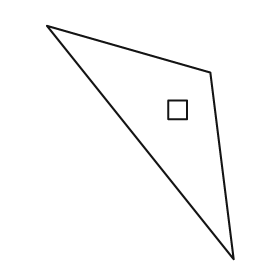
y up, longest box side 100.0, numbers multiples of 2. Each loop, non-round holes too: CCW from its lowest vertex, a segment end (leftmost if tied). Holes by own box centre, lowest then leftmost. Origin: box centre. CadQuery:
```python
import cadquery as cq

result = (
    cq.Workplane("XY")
    .moveTo(40.0, -50.0)
    .lineTo(30.0, 30.0)
    .lineTo(-40.0, 50.0)
    .close()
    .moveTo(12.0, 10.0)
    .lineTo(20.0, 10.0)
    .lineTo(20.0, 18.0)
    .lineTo(12.0, 18.0)
    .close()
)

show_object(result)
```